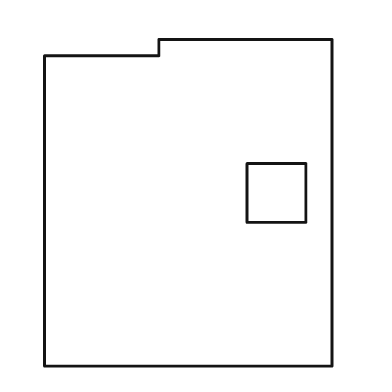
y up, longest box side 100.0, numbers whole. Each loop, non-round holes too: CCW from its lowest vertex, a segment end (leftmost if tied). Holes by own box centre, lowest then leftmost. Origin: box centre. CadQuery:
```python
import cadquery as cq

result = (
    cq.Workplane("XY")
    .moveTo(-44.0, -50.0)
    .lineTo(44.0, -50.0)
    .lineTo(44.0, 50.0)
    .lineTo(-9.0, 50.0)
    .lineTo(-9.0, 45.0)
    .lineTo(-44.0, 45.0)
    .close()
    .moveTo(18.0, -6.0)
    .lineTo(36.0, -6.0)
    .lineTo(36.0, 12.0)
    .lineTo(18.0, 12.0)
    .close()
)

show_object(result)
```